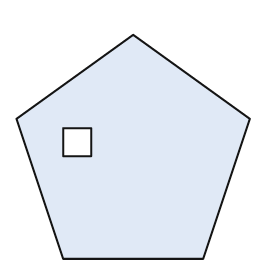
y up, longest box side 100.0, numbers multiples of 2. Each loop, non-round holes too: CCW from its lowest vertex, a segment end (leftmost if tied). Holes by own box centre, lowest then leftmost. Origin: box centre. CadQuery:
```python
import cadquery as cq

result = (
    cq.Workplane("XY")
    .moveTo(-30.0, -48.0)
    .lineTo(30.0, -48.0)
    .lineTo(50.0, 12.0)
    .lineTo(0.0, 48.0)
    .lineTo(-50.0, 12.0)
    .close()
    .moveTo(-30.0, -4.0)
    .lineTo(-18.0, -4.0)
    .lineTo(-18.0, 8.0)
    .lineTo(-30.0, 8.0)
    .close()
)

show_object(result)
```